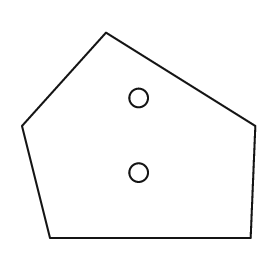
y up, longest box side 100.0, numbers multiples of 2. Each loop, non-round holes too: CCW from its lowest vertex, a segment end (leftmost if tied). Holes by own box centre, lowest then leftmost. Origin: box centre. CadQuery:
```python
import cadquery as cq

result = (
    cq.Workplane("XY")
    .moveTo(-38.0, -44.0)
    .lineTo(48.0, -44.0)
    .lineTo(50.0, 4.0)
    .lineTo(-14.0, 44.0)
    .lineTo(-50.0, 4.0)
    .close()
    .moveTo(0.0, -16.0)
    .circle(4.0)
    .moveTo(0.0, 16.0)
    .circle(4.0)
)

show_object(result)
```